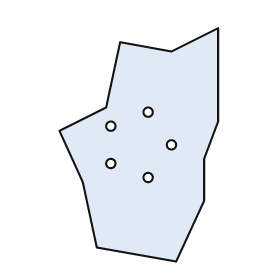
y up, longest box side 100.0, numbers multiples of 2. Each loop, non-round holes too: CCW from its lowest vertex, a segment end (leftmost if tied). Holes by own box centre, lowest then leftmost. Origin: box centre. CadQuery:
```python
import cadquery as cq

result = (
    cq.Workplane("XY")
    .moveTo(16.0, -50.0)
    .lineTo(28.0, -24.0)
    .lineTo(28.0, -6.0)
    .lineTo(34.0, 10.0)
    .lineTo(34.0, 50.0)
    .lineTo(14.0, 40.0)
    .lineTo(-8.0, 44.0)
    .lineTo(-14.0, 16.0)
    .lineTo(-34.0, 6.0)
    .lineTo(-24.0, -16.0)
    .lineTo(-18.0, -44.0)
    .close()
    .moveTo(4.0, -14.0)
    .circle(2.0)
    .moveTo(-12.0, -8.0)
    .circle(2.0)
    .moveTo(14.0, 0.0)
    .circle(2.0)
    .moveTo(-12.0, 8.0)
    .circle(2.0)
    .moveTo(4.0, 14.0)
    .circle(2.0)
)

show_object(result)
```